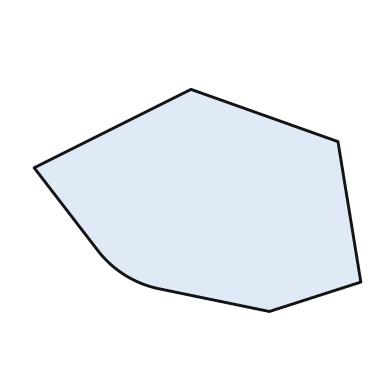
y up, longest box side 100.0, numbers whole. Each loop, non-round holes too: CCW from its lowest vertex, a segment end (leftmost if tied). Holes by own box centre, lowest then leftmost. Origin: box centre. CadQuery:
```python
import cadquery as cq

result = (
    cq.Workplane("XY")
    .moveTo(22.0, -34.0)
    .lineTo(50.0, -25.0)
    .lineTo(43.0, 18.0)
    .lineTo(-2.0, 34.0)
    .lineTo(-50.0, 10.0)
    .lineTo(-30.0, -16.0)
    .threePointArc((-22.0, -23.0), (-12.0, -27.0))
    .close()
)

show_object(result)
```